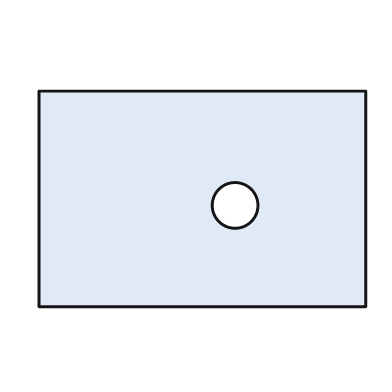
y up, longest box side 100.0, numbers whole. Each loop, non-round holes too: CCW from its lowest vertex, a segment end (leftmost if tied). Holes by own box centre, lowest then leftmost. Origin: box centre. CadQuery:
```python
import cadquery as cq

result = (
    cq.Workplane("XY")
    .moveTo(-50.0, -33.0)
    .lineTo(50.0, -33.0)
    .lineTo(50.0, 33.0)
    .lineTo(-50.0, 33.0)
    .close()
    .moveTo(10.0, -2.0)
    .circle(7.0)
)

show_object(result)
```